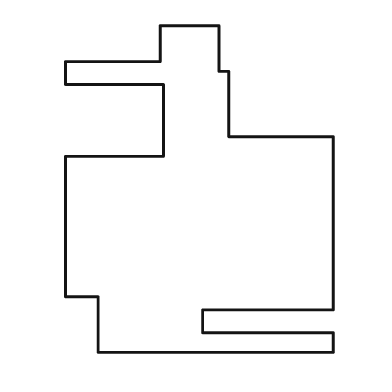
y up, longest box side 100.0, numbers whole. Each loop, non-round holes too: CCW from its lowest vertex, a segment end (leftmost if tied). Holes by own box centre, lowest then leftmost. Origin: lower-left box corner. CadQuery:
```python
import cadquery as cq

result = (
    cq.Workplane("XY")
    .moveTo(10.0, 0.0)
    .lineTo(82.0, 0.0)
    .lineTo(82.0, 6.0)
    .lineTo(42.0, 6.0)
    .lineTo(42.0, 13.0)
    .lineTo(82.0, 13.0)
    .lineTo(82.0, 66.0)
    .lineTo(50.0, 66.0)
    .lineTo(50.0, 86.0)
    .lineTo(47.0, 86.0)
    .lineTo(47.0, 100.0)
    .lineTo(29.0, 100.0)
    .lineTo(29.0, 89.0)
    .lineTo(0.0, 89.0)
    .lineTo(0.0, 82.0)
    .lineTo(30.0, 82.0)
    .lineTo(30.0, 60.0)
    .lineTo(0.0, 60.0)
    .lineTo(0.0, 17.0)
    .lineTo(10.0, 17.0)
    .close()
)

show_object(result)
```